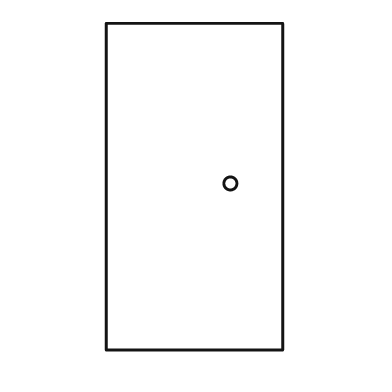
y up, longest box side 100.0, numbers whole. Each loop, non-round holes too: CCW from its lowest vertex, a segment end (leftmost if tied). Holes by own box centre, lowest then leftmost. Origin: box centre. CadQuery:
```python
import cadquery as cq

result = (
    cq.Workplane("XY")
    .moveTo(-27.0, -50.0)
    .lineTo(27.0, -50.0)
    .lineTo(27.0, 50.0)
    .lineTo(-27.0, 50.0)
    .close()
    .moveTo(11.0, 1.0)
    .circle(2.0)
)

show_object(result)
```